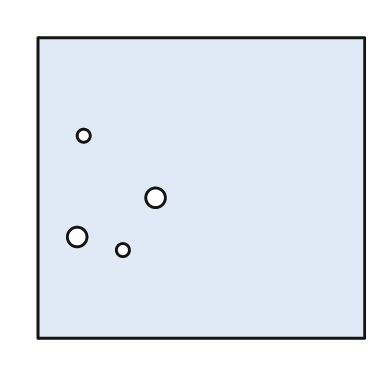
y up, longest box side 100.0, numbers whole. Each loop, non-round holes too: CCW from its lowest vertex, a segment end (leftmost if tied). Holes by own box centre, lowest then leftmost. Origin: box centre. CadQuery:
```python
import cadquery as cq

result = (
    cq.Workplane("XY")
    .moveTo(-50.0, -46.0)
    .lineTo(50.0, -46.0)
    .lineTo(50.0, 46.0)
    .lineTo(-50.0, 46.0)
    .close()
    .moveTo(-24.0, -19.0)
    .circle(2.0)
    .moveTo(-38.0, -15.0)
    .circle(3.0)
    .moveTo(-14.0, -3.0)
    .circle(3.0)
    .moveTo(-36.0, 16.0)
    .circle(2.0)
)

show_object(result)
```